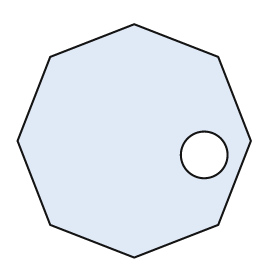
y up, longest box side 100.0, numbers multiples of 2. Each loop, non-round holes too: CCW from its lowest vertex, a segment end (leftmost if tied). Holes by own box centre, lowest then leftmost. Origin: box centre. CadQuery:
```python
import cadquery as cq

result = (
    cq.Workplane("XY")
    .moveTo(0.0, -50.0)
    .lineTo(36.0, -36.0)
    .lineTo(50.0, 0.0)
    .lineTo(36.0, 36.0)
    .lineTo(0.0, 50.0)
    .lineTo(-36.0, 36.0)
    .lineTo(-50.0, 0.0)
    .lineTo(-36.0, -36.0)
    .close()
    .moveTo(30.0, -6.0)
    .circle(10.0)
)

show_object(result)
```